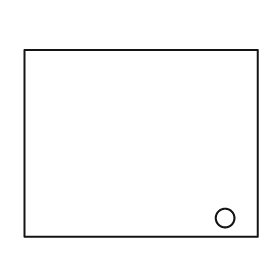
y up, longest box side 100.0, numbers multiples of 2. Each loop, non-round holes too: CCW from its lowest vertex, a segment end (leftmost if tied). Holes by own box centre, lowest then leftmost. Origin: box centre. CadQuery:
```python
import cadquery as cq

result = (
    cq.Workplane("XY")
    .moveTo(-50.0, -40.0)
    .lineTo(50.0, -40.0)
    .lineTo(50.0, 40.0)
    .lineTo(-50.0, 40.0)
    .close()
    .moveTo(36.0, -32.0)
    .circle(4.0)
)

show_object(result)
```